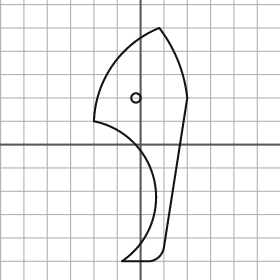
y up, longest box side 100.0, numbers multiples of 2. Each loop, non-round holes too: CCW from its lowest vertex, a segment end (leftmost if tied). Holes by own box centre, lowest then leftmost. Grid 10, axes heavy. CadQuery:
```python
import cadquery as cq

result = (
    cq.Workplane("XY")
    .moveTo(-8.0, -50.0)
    .lineTo(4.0, -50.0)
    .threePointArc((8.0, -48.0), (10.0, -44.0))
    .lineTo(20.0, 20.0)
    .threePointArc((16.0, 36.0), (8.0, 50.0))
    .threePointArc((-12.0, 34.0), (-20.0, 10.0))
    .threePointArc((6.0, -16.0), (-8.0, -50.0))
    .close()
    .moveTo(-2.0, 20.0)
    .circle(2.0)
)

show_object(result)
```